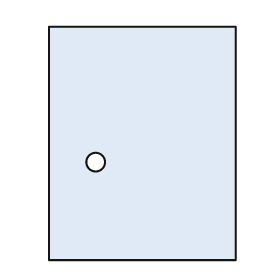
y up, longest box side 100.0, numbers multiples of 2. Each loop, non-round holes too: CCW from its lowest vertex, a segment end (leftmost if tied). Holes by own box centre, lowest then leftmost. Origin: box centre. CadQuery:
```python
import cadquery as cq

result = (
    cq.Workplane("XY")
    .moveTo(-40.0, -50.0)
    .lineTo(40.0, -50.0)
    .lineTo(40.0, 50.0)
    .lineTo(-40.0, 50.0)
    .close()
    .moveTo(-20.0, -8.0)
    .circle(4.0)
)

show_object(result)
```